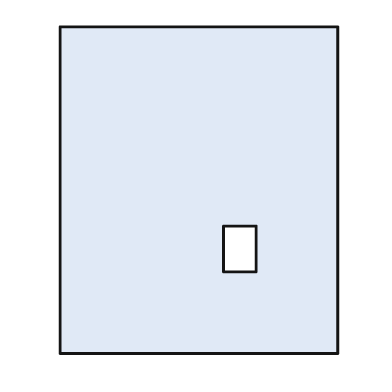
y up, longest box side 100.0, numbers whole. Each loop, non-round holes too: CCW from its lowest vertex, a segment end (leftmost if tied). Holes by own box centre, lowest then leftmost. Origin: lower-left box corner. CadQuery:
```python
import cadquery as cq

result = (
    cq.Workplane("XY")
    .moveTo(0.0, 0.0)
    .lineTo(85.0, 0.0)
    .lineTo(85.0, 100.0)
    .lineTo(0.0, 100.0)
    .close()
    .moveTo(50.0, 25.0)
    .lineTo(60.0, 25.0)
    .lineTo(60.0, 39.0)
    .lineTo(50.0, 39.0)
    .close()
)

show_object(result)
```